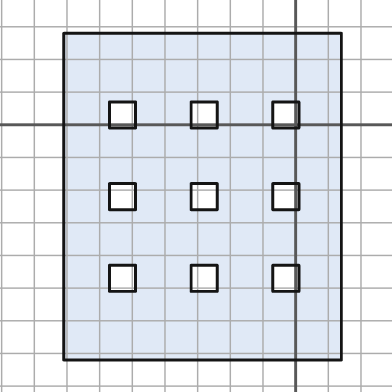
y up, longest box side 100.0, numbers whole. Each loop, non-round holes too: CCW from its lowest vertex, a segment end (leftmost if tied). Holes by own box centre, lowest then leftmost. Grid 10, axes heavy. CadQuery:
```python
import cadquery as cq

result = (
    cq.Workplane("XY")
    .moveTo(-71.0, -72.0)
    .lineTo(14.0, -72.0)
    .lineTo(14.0, 28.0)
    .lineTo(-71.0, 28.0)
    .close()
    .moveTo(-57.0, -51.0)
    .lineTo(-49.0, -51.0)
    .lineTo(-49.0, -43.0)
    .lineTo(-57.0, -43.0)
    .close()
    .moveTo(-32.0, -51.0)
    .lineTo(-24.0, -51.0)
    .lineTo(-24.0, -43.0)
    .lineTo(-32.0, -43.0)
    .close()
    .moveTo(-7.0, -51.0)
    .lineTo(1.0, -51.0)
    .lineTo(1.0, -43.0)
    .lineTo(-7.0, -43.0)
    .close()
    .moveTo(-57.0, -26.0)
    .lineTo(-49.0, -26.0)
    .lineTo(-49.0, -18.0)
    .lineTo(-57.0, -18.0)
    .close()
    .moveTo(-32.0, -26.0)
    .lineTo(-24.0, -26.0)
    .lineTo(-24.0, -18.0)
    .lineTo(-32.0, -18.0)
    .close()
    .moveTo(-7.0, -26.0)
    .lineTo(1.0, -26.0)
    .lineTo(1.0, -18.0)
    .lineTo(-7.0, -18.0)
    .close()
    .moveTo(-57.0, -1.0)
    .lineTo(-49.0, -1.0)
    .lineTo(-49.0, 7.0)
    .lineTo(-57.0, 7.0)
    .close()
    .moveTo(-32.0, -1.0)
    .lineTo(-24.0, -1.0)
    .lineTo(-24.0, 7.0)
    .lineTo(-32.0, 7.0)
    .close()
    .moveTo(-7.0, -1.0)
    .lineTo(1.0, -1.0)
    .lineTo(1.0, 7.0)
    .lineTo(-7.0, 7.0)
    .close()
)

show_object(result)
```